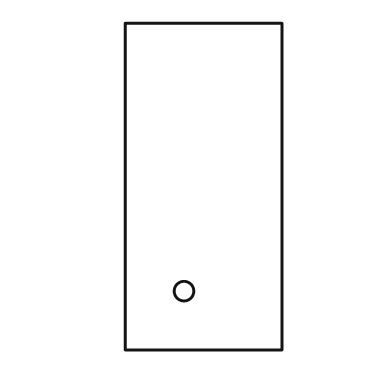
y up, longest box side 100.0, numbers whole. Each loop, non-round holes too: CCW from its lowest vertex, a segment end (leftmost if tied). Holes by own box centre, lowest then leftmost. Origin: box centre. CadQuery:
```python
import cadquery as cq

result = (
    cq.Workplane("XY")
    .moveTo(-24.0, -50.0)
    .lineTo(24.0, -50.0)
    .lineTo(24.0, 50.0)
    .lineTo(-24.0, 50.0)
    .close()
    .moveTo(-6.0, -32.0)
    .circle(3.0)
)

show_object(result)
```